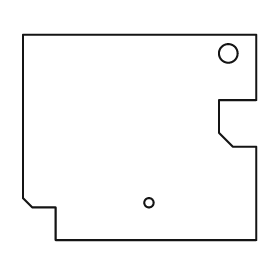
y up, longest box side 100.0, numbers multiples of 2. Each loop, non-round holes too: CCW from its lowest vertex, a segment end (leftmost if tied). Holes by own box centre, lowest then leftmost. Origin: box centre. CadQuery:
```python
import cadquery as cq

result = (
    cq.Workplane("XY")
    .moveTo(-36.0, -44.0)
    .lineTo(50.0, -44.0)
    .lineTo(50.0, -4.0)
    .lineTo(40.0, -4.0)
    .lineTo(34.0, 2.0)
    .lineTo(34.0, 16.0)
    .lineTo(50.0, 16.0)
    .lineTo(50.0, 44.0)
    .lineTo(-50.0, 44.0)
    .lineTo(-50.0, -26.0)
    .lineTo(-46.0, -30.0)
    .lineTo(-36.0, -30.0)
    .close()
    .moveTo(4.0, -28.0)
    .circle(2.0)
    .moveTo(38.0, 36.0)
    .circle(4.0)
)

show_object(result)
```